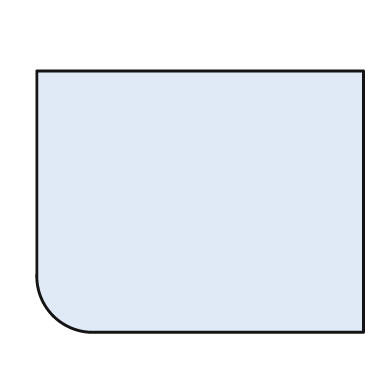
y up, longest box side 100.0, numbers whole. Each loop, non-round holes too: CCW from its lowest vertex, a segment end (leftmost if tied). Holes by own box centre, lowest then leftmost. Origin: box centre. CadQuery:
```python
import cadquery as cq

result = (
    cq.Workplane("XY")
    .moveTo(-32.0, -40.0)
    .lineTo(50.0, -40.0)
    .lineTo(50.0, 40.0)
    .lineTo(-50.0, 40.0)
    .lineTo(-50.0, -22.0)
    .threePointArc((-45.0, -35.0), (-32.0, -40.0))
    .close()
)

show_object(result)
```